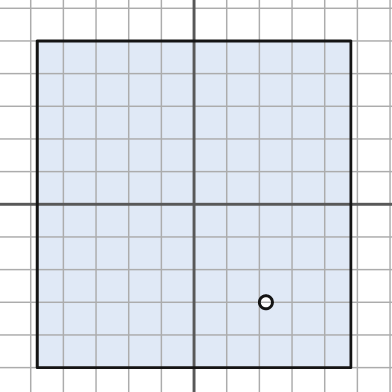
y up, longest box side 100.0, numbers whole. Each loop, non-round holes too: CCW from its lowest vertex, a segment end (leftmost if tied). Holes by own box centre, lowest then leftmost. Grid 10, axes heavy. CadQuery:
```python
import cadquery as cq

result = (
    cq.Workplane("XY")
    .moveTo(-48.0, -50.0)
    .lineTo(48.0, -50.0)
    .lineTo(48.0, 50.0)
    .lineTo(-48.0, 50.0)
    .close()
    .moveTo(22.0, -30.0)
    .circle(2.0)
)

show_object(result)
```